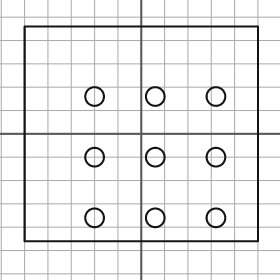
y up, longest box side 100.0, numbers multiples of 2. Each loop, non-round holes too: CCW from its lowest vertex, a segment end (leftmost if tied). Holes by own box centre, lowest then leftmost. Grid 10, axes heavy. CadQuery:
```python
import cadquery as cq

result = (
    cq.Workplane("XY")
    .moveTo(-50.0, -46.0)
    .lineTo(50.0, -46.0)
    .lineTo(50.0, 46.0)
    .lineTo(-50.0, 46.0)
    .close()
    .moveTo(-20.0, -36.0)
    .circle(4.0)
    .moveTo(6.0, -36.0)
    .circle(4.0)
    .moveTo(32.0, -36.0)
    .circle(4.0)
    .moveTo(-20.0, -10.0)
    .circle(4.0)
    .moveTo(6.0, -10.0)
    .circle(4.0)
    .moveTo(32.0, -10.0)
    .circle(4.0)
    .moveTo(-20.0, 16.0)
    .circle(4.0)
    .moveTo(6.0, 16.0)
    .circle(4.0)
    .moveTo(32.0, 16.0)
    .circle(4.0)
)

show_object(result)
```